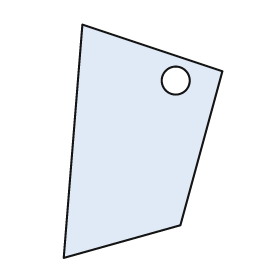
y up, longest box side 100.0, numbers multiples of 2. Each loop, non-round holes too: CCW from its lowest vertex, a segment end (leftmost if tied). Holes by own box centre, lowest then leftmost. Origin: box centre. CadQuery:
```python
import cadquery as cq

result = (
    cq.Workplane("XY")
    .moveTo(-34.0, -50.0)
    .lineTo(16.0, -36.0)
    .lineTo(34.0, 30.0)
    .lineTo(-26.0, 50.0)
    .close()
    .moveTo(14.0, 26.0)
    .circle(6.0)
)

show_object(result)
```